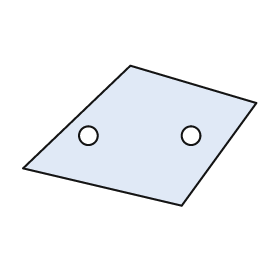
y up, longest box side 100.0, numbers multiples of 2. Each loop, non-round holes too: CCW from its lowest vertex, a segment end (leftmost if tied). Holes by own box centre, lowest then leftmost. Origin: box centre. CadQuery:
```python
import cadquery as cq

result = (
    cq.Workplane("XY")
    .moveTo(18.0, -30.0)
    .lineTo(50.0, 14.0)
    .lineTo(-4.0, 30.0)
    .lineTo(-50.0, -14.0)
    .close()
    .moveTo(-22.0, 0.0)
    .circle(4.0)
    .moveTo(22.0, 0.0)
    .circle(4.0)
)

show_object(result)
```